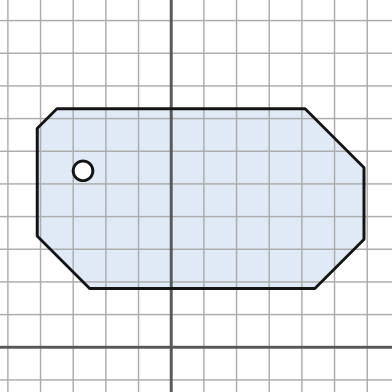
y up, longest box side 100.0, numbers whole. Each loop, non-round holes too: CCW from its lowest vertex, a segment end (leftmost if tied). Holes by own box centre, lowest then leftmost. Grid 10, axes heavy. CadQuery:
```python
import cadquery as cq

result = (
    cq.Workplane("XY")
    .moveTo(-25.0, 18.0)
    .lineTo(44.0, 18.0)
    .lineTo(59.0, 33.0)
    .lineTo(59.0, 55.0)
    .lineTo(41.0, 73.0)
    .lineTo(-35.0, 73.0)
    .lineTo(-41.0, 67.0)
    .lineTo(-41.0, 34.0)
    .close()
    .moveTo(-27.0, 54.0)
    .circle(3.0)
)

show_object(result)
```